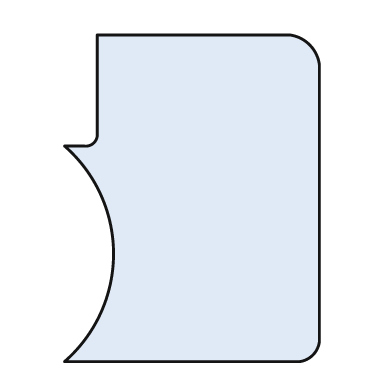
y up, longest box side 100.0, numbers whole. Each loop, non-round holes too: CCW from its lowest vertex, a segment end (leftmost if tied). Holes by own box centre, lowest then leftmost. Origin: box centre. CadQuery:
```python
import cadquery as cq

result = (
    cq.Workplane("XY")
    .moveTo(-39.0, -50.0)
    .lineTo(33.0, -50.0)
    .threePointArc((37.0, -48.0), (39.0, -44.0))
    .lineTo(39.0, 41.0)
    .threePointArc((36.0, 47.0), (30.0, 50.0))
    .lineTo(-29.0, 50.0)
    .lineTo(-29.0, 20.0)
    .threePointArc((-30.0, 17.0), (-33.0, 16.0))
    .lineTo(-39.0, 16.0)
    .threePointArc((-24.0, -17.0), (-39.0, -50.0))
    .close()
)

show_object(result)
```